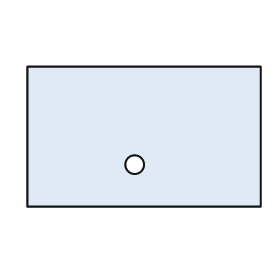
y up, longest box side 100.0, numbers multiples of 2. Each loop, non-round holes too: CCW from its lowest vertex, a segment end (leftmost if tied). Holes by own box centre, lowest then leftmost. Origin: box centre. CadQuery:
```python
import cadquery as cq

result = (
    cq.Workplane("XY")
    .moveTo(-50.0, -30.0)
    .lineTo(50.0, -30.0)
    .lineTo(50.0, 30.0)
    .lineTo(-50.0, 30.0)
    .close()
    .moveTo(-4.0, -12.0)
    .circle(4.0)
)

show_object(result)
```